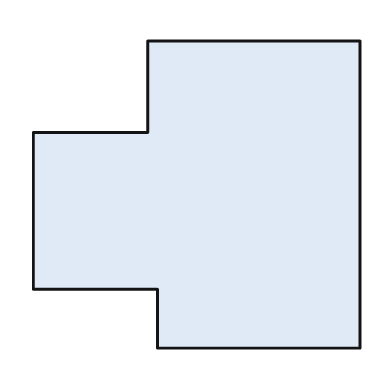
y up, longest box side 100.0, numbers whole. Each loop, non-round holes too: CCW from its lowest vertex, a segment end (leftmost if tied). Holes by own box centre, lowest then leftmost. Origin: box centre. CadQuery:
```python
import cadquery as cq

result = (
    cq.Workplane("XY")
    .moveTo(-12.0, -47.0)
    .lineTo(50.0, -47.0)
    .lineTo(50.0, 47.0)
    .lineTo(-15.0, 47.0)
    .lineTo(-15.0, 19.0)
    .lineTo(-50.0, 19.0)
    .lineTo(-50.0, -29.0)
    .lineTo(-12.0, -29.0)
    .close()
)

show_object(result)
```